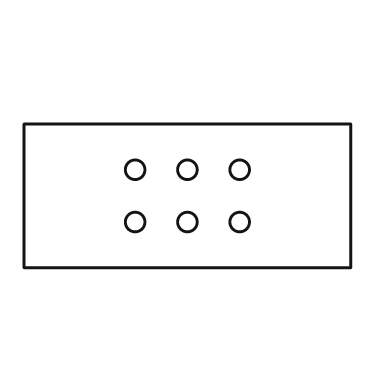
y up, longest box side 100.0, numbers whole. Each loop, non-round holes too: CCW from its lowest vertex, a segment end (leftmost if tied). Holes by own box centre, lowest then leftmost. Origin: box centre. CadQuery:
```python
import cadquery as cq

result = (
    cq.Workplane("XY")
    .moveTo(-50.0, -22.0)
    .lineTo(50.0, -22.0)
    .lineTo(50.0, 22.0)
    .lineTo(-50.0, 22.0)
    .close()
    .moveTo(-16.0, -8.0)
    .circle(3.0)
    .moveTo(0.0, -8.0)
    .circle(3.0)
    .moveTo(16.0, -8.0)
    .circle(3.0)
    .moveTo(-16.0, 8.0)
    .circle(3.0)
    .moveTo(0.0, 8.0)
    .circle(3.0)
    .moveTo(16.0, 8.0)
    .circle(3.0)
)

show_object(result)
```